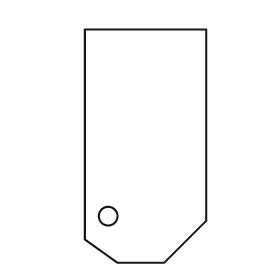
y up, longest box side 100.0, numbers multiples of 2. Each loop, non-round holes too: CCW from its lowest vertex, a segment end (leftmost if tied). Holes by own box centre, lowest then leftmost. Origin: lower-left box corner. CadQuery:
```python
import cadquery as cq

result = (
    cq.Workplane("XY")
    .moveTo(14.0, 0.0)
    .lineTo(34.0, 0.0)
    .lineTo(52.0, 18.0)
    .lineTo(52.0, 100.0)
    .lineTo(0.0, 100.0)
    .lineTo(0.0, 10.0)
    .close()
    .moveTo(10.0, 20.0)
    .circle(4.0)
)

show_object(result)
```